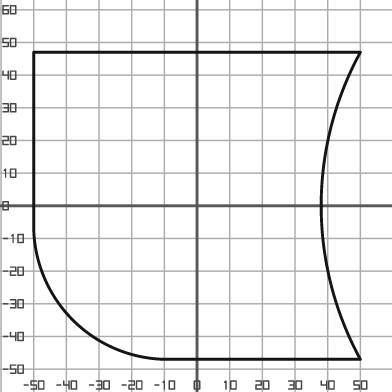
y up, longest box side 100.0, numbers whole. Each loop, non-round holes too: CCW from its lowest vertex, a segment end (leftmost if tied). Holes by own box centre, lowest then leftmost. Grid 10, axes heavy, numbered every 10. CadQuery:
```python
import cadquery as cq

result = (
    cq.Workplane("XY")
    .moveTo(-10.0, -47.0)
    .lineTo(50.0, -47.0)
    .threePointArc((38.0, 0.0), (50.0, 47.0))
    .lineTo(-50.0, 47.0)
    .lineTo(-50.0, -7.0)
    .threePointArc((-38.0, -35.0), (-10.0, -47.0))
    .close()
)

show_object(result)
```